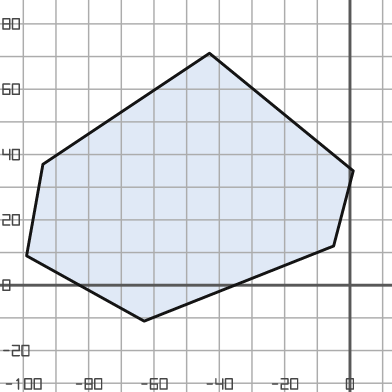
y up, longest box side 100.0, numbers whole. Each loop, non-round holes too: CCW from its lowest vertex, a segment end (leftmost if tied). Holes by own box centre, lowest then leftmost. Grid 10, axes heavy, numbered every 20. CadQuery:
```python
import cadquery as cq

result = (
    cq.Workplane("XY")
    .moveTo(-63.0, -11.0)
    .lineTo(-5.0, 12.0)
    .lineTo(1.0, 35.0)
    .lineTo(-43.0, 71.0)
    .lineTo(-94.0, 37.0)
    .lineTo(-99.0, 9.0)
    .close()
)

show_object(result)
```